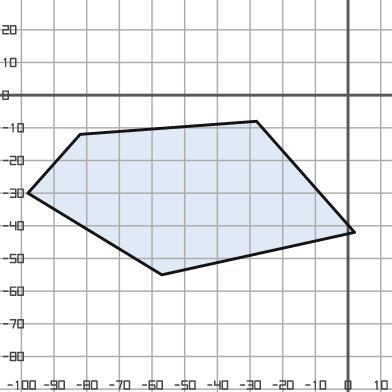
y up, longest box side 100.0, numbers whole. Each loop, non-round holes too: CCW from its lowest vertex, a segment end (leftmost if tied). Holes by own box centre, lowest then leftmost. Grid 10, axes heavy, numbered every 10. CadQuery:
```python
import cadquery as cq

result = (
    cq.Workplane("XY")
    .moveTo(-57.0, -55.0)
    .lineTo(2.0, -42.0)
    .lineTo(-28.0, -8.0)
    .lineTo(-82.0, -12.0)
    .lineTo(-98.0, -30.0)
    .close()
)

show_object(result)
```